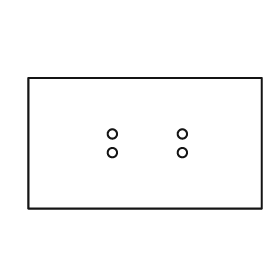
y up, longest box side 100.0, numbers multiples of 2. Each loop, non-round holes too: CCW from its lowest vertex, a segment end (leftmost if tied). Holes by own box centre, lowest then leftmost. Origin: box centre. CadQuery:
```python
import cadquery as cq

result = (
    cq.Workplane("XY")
    .moveTo(-50.0, -28.0)
    .lineTo(50.0, -28.0)
    .lineTo(50.0, 28.0)
    .lineTo(-50.0, 28.0)
    .close()
    .moveTo(-14.0, -4.0)
    .circle(2.0)
    .moveTo(16.0, -4.0)
    .circle(2.0)
    .moveTo(-14.0, 4.0)
    .circle(2.0)
    .moveTo(16.0, 4.0)
    .circle(2.0)
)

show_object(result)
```